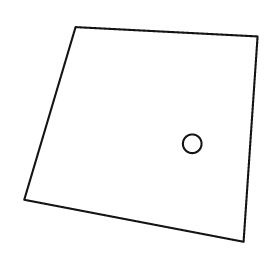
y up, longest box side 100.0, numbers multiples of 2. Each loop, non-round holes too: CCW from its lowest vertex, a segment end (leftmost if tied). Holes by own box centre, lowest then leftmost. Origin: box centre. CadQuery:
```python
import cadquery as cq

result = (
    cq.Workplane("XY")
    .moveTo(44.0, -46.0)
    .lineTo(50.0, 42.0)
    .lineTo(-28.0, 46.0)
    .lineTo(-50.0, -28.0)
    .close()
    .moveTo(22.0, -4.0)
    .circle(4.0)
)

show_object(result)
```